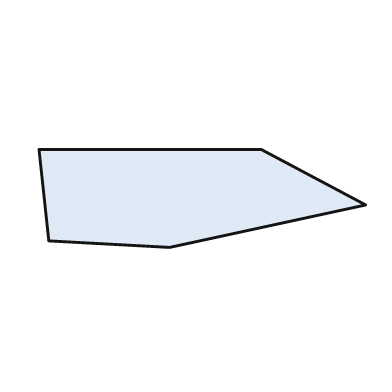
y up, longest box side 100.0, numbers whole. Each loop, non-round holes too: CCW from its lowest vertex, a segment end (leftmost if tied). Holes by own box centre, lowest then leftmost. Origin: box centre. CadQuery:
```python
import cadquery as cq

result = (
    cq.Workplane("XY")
    .moveTo(-10.0, -15.0)
    .lineTo(50.0, -2.0)
    .lineTo(18.0, 15.0)
    .lineTo(-50.0, 15.0)
    .lineTo(-47.0, -13.0)
    .close()
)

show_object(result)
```